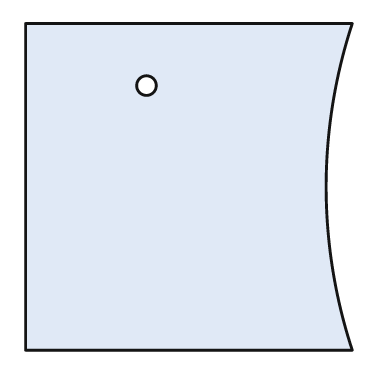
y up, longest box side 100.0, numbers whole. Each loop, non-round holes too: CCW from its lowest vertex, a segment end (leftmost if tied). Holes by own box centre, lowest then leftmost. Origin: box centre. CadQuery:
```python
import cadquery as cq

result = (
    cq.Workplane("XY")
    .moveTo(-50.0, -50.0)
    .lineTo(50.0, -50.0)
    .threePointArc((42.0, 0.0), (50.0, 50.0))
    .lineTo(-50.0, 50.0)
    .close()
    .moveTo(-13.0, 31.0)
    .circle(3.0)
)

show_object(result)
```